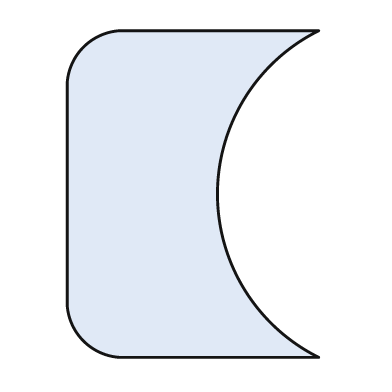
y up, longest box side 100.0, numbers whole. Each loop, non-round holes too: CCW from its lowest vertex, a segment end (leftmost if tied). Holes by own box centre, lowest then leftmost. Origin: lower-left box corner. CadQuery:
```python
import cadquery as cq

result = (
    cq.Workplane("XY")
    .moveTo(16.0, 0.0)
    .lineTo(77.0, 0.0)
    .threePointArc((46.0, 50.0), (77.0, 100.0))
    .lineTo(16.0, 100.0)
    .threePointArc((5.0, 95.0), (0.0, 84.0))
    .lineTo(0.0, 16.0)
    .threePointArc((5.0, 5.0), (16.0, 0.0))
    .close()
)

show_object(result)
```